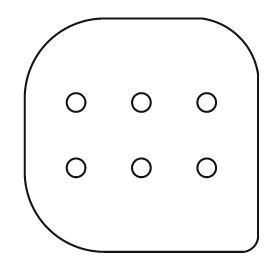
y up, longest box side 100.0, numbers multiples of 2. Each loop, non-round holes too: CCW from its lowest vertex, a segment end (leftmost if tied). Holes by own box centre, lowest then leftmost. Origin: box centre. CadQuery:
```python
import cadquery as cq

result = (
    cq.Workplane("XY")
    .moveTo(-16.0, -50.0)
    .lineTo(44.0, -50.0)
    .threePointArc((48.0, -48.0), (50.0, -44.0))
    .lineTo(50.0, 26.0)
    .threePointArc((42.0, 42.0), (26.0, 50.0))
    .lineTo(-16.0, 50.0)
    .threePointArc((-40.0, 40.0), (-50.0, 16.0))
    .lineTo(-50.0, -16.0)
    .threePointArc((-40.0, -40.0), (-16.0, -50.0))
    .close()
    .moveTo(-28.0, -14.0)
    .circle(4.0)
    .moveTo(0.0, -14.0)
    .circle(4.0)
    .moveTo(28.0, -14.0)
    .circle(4.0)
    .moveTo(-28.0, 14.0)
    .circle(4.0)
    .moveTo(0.0, 14.0)
    .circle(4.0)
    .moveTo(28.0, 14.0)
    .circle(4.0)
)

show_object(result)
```